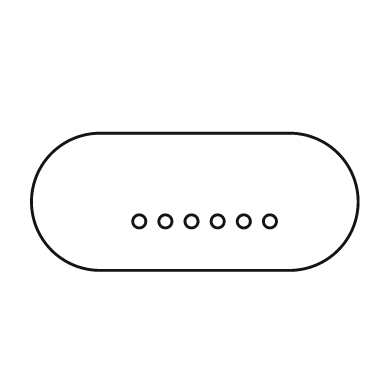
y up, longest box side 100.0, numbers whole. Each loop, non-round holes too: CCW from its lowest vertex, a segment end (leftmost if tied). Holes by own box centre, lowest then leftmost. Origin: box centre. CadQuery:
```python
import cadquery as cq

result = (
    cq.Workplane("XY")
    .moveTo(-29.0, -21.0)
    .lineTo(29.0, -21.0)
    .threePointArc((50.0, 0.0), (29.0, 21.0))
    .lineTo(-29.0, 21.0)
    .threePointArc((-50.0, 0.0), (-29.0, -21.0))
    .close()
    .moveTo(-17.0, -6.0)
    .circle(2.0)
    .moveTo(-9.0, -6.0)
    .circle(2.0)
    .moveTo(-1.0, -6.0)
    .circle(2.0)
    .moveTo(7.0, -6.0)
    .circle(2.0)
    .moveTo(15.0, -6.0)
    .circle(2.0)
    .moveTo(23.0, -6.0)
    .circle(2.0)
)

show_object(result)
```